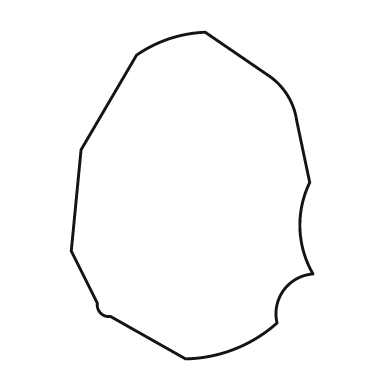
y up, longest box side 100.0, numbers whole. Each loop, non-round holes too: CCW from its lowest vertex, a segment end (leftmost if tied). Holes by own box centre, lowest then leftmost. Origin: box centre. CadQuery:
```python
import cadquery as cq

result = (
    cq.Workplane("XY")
    .moveTo(-2.0, -50.0)
    .threePointArc((13.0, -47.0), (26.0, -39.0))
    .threePointArc((28.0, -29.0), (37.0, -24.0))
    .threePointArc((33.0, -10.0), (36.0, 4.0))
    .lineTo(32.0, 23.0)
    .threePointArc((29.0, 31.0), (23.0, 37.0))
    .lineTo(4.0, 50.0)
    .threePointArc((-7.0, 48.0), (-17.0, 43.0))
    .lineTo(-34.0, 14.0)
    .lineTo(-37.0, -17.0)
    .lineTo(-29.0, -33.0)
    .threePointArc((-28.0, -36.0), (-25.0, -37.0))
    .close()
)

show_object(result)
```